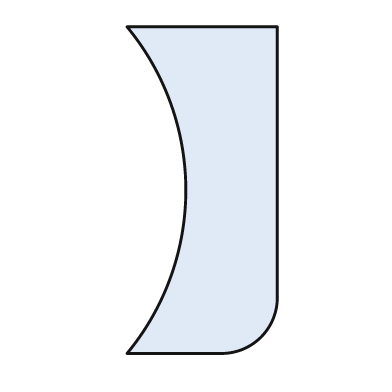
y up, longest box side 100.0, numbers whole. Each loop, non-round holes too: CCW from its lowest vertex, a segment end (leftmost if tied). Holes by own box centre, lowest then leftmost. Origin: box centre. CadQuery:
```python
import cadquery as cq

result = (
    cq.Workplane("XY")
    .moveTo(-23.0, -50.0)
    .lineTo(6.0, -50.0)
    .threePointArc((18.0, -45.0), (23.0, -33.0))
    .lineTo(23.0, 50.0)
    .lineTo(-23.0, 50.0)
    .threePointArc((-5.0, 0.0), (-23.0, -50.0))
    .close()
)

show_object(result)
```